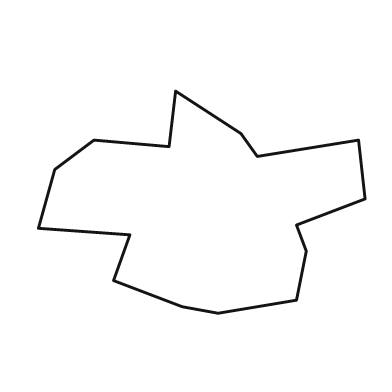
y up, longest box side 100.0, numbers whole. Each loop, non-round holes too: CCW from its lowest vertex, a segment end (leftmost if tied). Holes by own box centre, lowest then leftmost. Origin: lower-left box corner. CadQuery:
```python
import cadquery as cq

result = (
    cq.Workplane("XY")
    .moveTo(55.0, 0.0)
    .lineTo(79.0, 4.0)
    .lineTo(82.0, 19.0)
    .lineTo(79.0, 27.0)
    .lineTo(100.0, 35.0)
    .lineTo(98.0, 53.0)
    .lineTo(67.0, 48.0)
    .lineTo(62.0, 55.0)
    .lineTo(42.0, 68.0)
    .lineTo(40.0, 51.0)
    .lineTo(17.0, 53.0)
    .lineTo(5.0, 44.0)
    .lineTo(0.0, 26.0)
    .lineTo(28.0, 24.0)
    .lineTo(23.0, 10.0)
    .lineTo(44.0, 2.0)
    .close()
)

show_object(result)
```